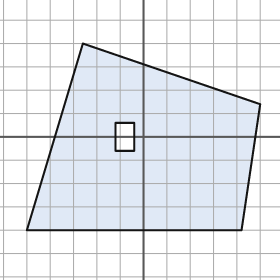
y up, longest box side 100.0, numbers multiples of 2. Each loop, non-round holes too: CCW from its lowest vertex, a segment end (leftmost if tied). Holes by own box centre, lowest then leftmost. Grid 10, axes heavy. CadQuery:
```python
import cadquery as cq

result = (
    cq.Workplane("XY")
    .moveTo(-50.0, -40.0)
    .lineTo(42.0, -40.0)
    .lineTo(50.0, 14.0)
    .lineTo(-26.0, 40.0)
    .close()
    .moveTo(-12.0, -6.0)
    .lineTo(-4.0, -6.0)
    .lineTo(-4.0, 6.0)
    .lineTo(-12.0, 6.0)
    .close()
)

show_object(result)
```